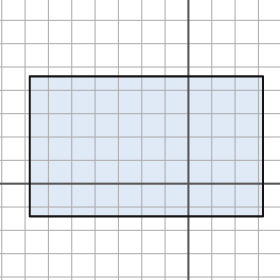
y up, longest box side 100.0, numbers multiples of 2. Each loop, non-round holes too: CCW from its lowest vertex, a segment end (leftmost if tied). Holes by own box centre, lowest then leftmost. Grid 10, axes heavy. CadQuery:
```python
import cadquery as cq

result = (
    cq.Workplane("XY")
    .moveTo(-68.0, -14.0)
    .lineTo(32.0, -14.0)
    .lineTo(32.0, 46.0)
    .lineTo(-68.0, 46.0)
    .close()
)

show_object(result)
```